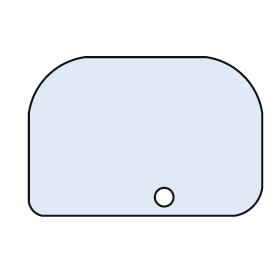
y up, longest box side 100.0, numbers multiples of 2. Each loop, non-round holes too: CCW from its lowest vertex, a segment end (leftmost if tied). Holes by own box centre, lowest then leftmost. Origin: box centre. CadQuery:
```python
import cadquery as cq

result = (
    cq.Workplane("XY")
    .moveTo(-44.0, -34.0)
    .lineTo(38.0, -34.0)
    .threePointArc((46.0, -30.0), (50.0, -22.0))
    .lineTo(50.0, 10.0)
    .threePointArc((42.0, 26.0), (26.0, 34.0))
    .lineTo(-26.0, 34.0)
    .threePointArc((-42.0, 26.0), (-50.0, 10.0))
    .lineTo(-50.0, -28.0)
    .threePointArc((-48.0, -32.0), (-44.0, -34.0))
    .close()
    .moveTo(8.0, -26.0)
    .circle(4.0)
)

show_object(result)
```